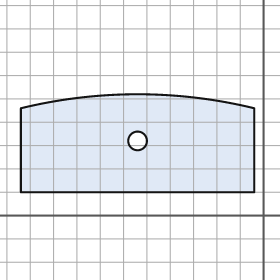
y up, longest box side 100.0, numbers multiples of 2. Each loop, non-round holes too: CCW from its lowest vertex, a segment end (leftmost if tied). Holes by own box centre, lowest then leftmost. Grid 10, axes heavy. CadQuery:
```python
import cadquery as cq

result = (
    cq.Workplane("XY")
    .moveTo(-104.0, 10.0)
    .lineTo(-4.0, 10.0)
    .lineTo(-4.0, 46.0)
    .threePointArc((-54.0, 52.0), (-104.0, 46.0))
    .close()
    .moveTo(-54.0, 32.0)
    .circle(4.0)
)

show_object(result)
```